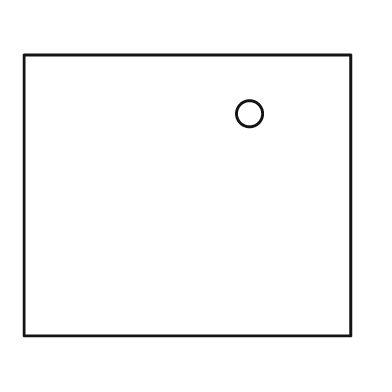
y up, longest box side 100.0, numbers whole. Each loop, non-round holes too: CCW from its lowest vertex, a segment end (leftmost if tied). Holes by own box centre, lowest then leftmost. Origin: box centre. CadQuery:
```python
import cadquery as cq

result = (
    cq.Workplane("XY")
    .moveTo(-50.0, -43.0)
    .lineTo(50.0, -43.0)
    .lineTo(50.0, 43.0)
    .lineTo(-50.0, 43.0)
    .close()
    .moveTo(19.0, 25.0)
    .circle(4.0)
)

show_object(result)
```